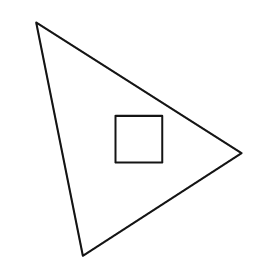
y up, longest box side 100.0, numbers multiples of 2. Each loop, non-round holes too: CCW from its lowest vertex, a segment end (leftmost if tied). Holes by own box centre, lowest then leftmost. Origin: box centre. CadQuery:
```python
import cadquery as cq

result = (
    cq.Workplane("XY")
    .moveTo(-24.0, -50.0)
    .lineTo(44.0, -6.0)
    .lineTo(-44.0, 50.0)
    .close()
    .moveTo(-10.0, -10.0)
    .lineTo(10.0, -10.0)
    .lineTo(10.0, 10.0)
    .lineTo(-10.0, 10.0)
    .close()
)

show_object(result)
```